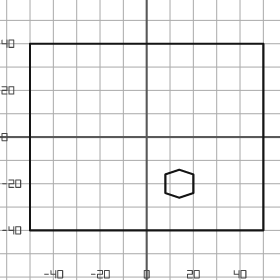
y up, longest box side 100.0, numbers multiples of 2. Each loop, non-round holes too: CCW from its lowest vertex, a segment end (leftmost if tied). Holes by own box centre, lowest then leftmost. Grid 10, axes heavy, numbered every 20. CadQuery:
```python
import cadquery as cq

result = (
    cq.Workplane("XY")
    .moveTo(-50.0, -40.0)
    .lineTo(50.0, -40.0)
    .lineTo(50.0, 40.0)
    .lineTo(-50.0, 40.0)
    .close()
    .moveTo(14.0, -26.0)
    .lineTo(20.0, -24.0)
    .lineTo(20.0, -16.0)
    .lineTo(14.0, -14.0)
    .lineTo(8.0, -16.0)
    .lineTo(8.0, -24.0)
    .close()
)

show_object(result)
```